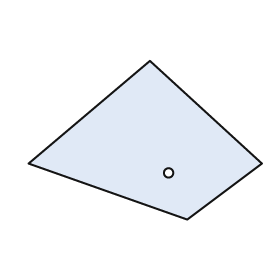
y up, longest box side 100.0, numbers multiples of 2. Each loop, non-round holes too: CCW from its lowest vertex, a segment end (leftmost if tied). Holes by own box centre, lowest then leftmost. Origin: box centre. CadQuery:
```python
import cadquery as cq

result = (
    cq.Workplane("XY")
    .moveTo(18.0, -34.0)
    .lineTo(50.0, -10.0)
    .lineTo(2.0, 34.0)
    .lineTo(-50.0, -10.0)
    .close()
    .moveTo(10.0, -14.0)
    .circle(2.0)
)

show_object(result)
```